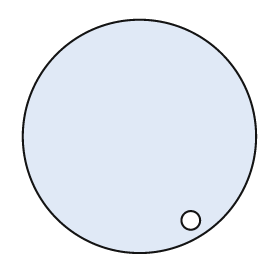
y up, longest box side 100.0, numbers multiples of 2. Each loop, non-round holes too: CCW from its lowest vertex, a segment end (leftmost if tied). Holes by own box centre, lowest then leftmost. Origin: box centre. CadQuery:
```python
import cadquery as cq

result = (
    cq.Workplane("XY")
    .moveTo(0.0, 0.0)
    .circle(50.0)
    .moveTo(22.0, -36.0)
    .circle(4.0)
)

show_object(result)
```